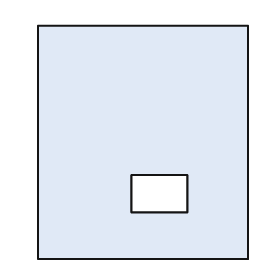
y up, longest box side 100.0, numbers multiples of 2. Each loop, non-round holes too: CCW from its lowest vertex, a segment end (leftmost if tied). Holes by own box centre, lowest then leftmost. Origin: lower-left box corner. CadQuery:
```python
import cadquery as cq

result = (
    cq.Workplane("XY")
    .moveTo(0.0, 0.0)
    .lineTo(90.0, 0.0)
    .lineTo(90.0, 100.0)
    .lineTo(0.0, 100.0)
    .close()
    .moveTo(40.0, 20.0)
    .lineTo(64.0, 20.0)
    .lineTo(64.0, 36.0)
    .lineTo(40.0, 36.0)
    .close()
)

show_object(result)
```